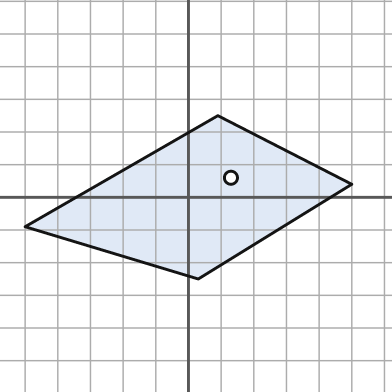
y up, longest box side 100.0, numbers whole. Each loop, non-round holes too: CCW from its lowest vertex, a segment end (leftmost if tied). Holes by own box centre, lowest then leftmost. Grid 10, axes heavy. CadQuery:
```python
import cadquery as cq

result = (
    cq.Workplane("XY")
    .moveTo(3.0, -25.0)
    .lineTo(50.0, 4.0)
    .lineTo(9.0, 25.0)
    .lineTo(-50.0, -9.0)
    .close()
    .moveTo(13.0, 6.0)
    .circle(2.0)
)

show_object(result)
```